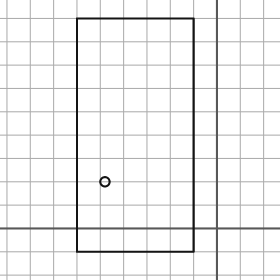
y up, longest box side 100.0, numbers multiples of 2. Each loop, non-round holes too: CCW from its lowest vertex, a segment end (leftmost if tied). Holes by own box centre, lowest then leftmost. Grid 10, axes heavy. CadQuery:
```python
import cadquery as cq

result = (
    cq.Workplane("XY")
    .moveTo(-60.0, -10.0)
    .lineTo(-10.0, -10.0)
    .lineTo(-10.0, 90.0)
    .lineTo(-60.0, 90.0)
    .close()
    .moveTo(-48.0, 20.0)
    .circle(2.0)
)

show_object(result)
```